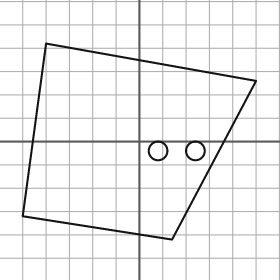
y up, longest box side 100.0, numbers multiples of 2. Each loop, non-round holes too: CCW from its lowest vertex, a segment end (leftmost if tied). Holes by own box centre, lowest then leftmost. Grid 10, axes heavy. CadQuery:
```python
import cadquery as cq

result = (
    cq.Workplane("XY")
    .moveTo(14.0, -42.0)
    .lineTo(50.0, 26.0)
    .lineTo(-40.0, 42.0)
    .lineTo(-50.0, -32.0)
    .close()
    .moveTo(8.0, -4.0)
    .circle(4.0)
    .moveTo(24.0, -4.0)
    .circle(4.0)
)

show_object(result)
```